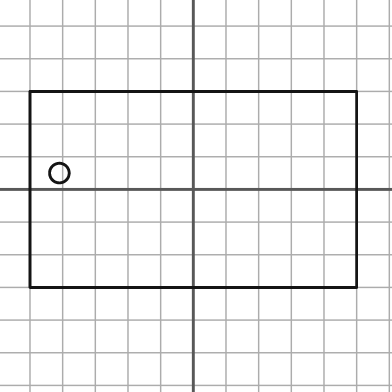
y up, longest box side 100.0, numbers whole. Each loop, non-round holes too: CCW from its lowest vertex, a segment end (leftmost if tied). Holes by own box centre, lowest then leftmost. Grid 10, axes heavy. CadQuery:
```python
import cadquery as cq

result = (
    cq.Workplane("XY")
    .moveTo(-50.0, -30.0)
    .lineTo(50.0, -30.0)
    .lineTo(50.0, 30.0)
    .lineTo(-50.0, 30.0)
    .close()
    .moveTo(-41.0, 5.0)
    .circle(3.0)
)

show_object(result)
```